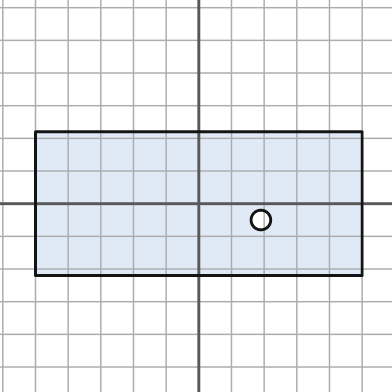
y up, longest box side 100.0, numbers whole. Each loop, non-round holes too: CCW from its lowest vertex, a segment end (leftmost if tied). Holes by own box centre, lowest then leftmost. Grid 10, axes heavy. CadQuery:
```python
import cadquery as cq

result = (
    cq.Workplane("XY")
    .moveTo(-50.0, -22.0)
    .lineTo(50.0, -22.0)
    .lineTo(50.0, 22.0)
    .lineTo(-50.0, 22.0)
    .close()
    .moveTo(19.0, -5.0)
    .circle(3.0)
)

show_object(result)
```